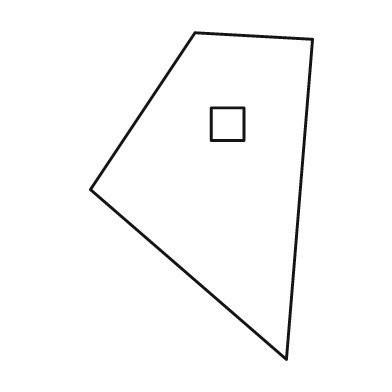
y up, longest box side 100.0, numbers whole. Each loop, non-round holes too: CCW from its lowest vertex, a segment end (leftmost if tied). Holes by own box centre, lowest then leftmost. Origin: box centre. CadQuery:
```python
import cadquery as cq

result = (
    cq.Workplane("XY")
    .moveTo(26.0, -50.0)
    .lineTo(34.0, 48.0)
    .lineTo(-2.0, 50.0)
    .lineTo(-34.0, 2.0)
    .close()
    .moveTo(3.0, 17.0)
    .lineTo(13.0, 17.0)
    .lineTo(13.0, 27.0)
    .lineTo(3.0, 27.0)
    .close()
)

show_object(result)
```